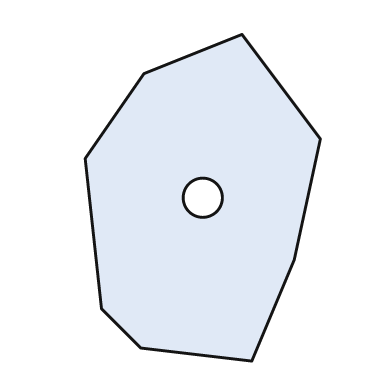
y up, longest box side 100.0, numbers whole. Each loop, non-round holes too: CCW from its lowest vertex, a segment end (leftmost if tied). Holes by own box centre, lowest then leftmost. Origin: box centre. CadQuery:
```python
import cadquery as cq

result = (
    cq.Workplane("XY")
    .moveTo(15.0, -50.0)
    .lineTo(28.0, -19.0)
    .lineTo(36.0, 18.0)
    .lineTo(12.0, 50.0)
    .lineTo(-18.0, 38.0)
    .lineTo(-36.0, 12.0)
    .lineTo(-31.0, -34.0)
    .lineTo(-19.0, -46.0)
    .close()
    .moveTo(0.0, 0.0)
    .circle(6.0)
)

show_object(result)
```